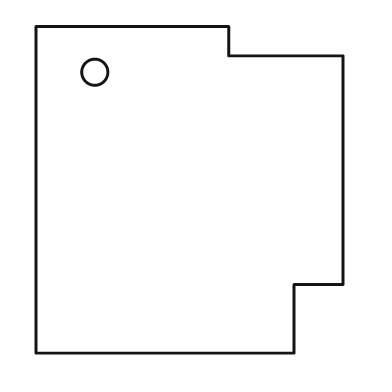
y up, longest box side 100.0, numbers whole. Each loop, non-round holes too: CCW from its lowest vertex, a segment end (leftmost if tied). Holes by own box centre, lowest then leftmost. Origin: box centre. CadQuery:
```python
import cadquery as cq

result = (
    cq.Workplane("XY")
    .moveTo(-47.0, -50.0)
    .lineTo(32.0, -50.0)
    .lineTo(32.0, -29.0)
    .lineTo(47.0, -29.0)
    .lineTo(47.0, 41.0)
    .lineTo(12.0, 41.0)
    .lineTo(12.0, 50.0)
    .lineTo(-47.0, 50.0)
    .close()
    .moveTo(-29.0, 36.0)
    .circle(4.0)
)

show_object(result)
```